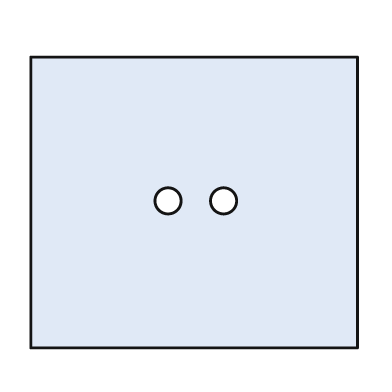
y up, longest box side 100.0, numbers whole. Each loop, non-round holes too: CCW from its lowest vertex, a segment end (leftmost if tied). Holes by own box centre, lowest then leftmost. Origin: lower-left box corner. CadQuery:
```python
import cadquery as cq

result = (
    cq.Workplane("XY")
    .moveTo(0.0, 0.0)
    .lineTo(100.0, 0.0)
    .lineTo(100.0, 89.0)
    .lineTo(0.0, 89.0)
    .close()
    .moveTo(42.0, 45.0)
    .circle(4.0)
    .moveTo(59.0, 45.0)
    .circle(4.0)
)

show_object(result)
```